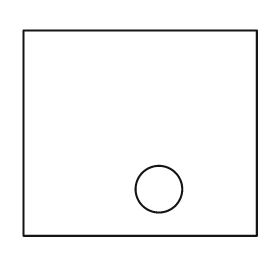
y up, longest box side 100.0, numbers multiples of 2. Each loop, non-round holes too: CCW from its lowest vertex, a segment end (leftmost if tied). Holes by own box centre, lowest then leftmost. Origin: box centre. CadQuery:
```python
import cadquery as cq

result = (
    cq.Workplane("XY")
    .moveTo(-50.0, -44.0)
    .lineTo(50.0, -44.0)
    .lineTo(50.0, 44.0)
    .lineTo(-50.0, 44.0)
    .close()
    .moveTo(8.0, -24.0)
    .circle(10.0)
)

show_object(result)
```